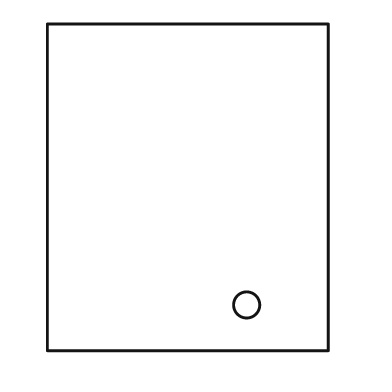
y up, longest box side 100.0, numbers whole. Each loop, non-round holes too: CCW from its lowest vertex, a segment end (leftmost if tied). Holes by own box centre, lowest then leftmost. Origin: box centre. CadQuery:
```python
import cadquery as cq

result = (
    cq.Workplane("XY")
    .moveTo(-43.0, -50.0)
    .lineTo(43.0, -50.0)
    .lineTo(43.0, 50.0)
    .lineTo(-43.0, 50.0)
    .close()
    .moveTo(18.0, -36.0)
    .circle(4.0)
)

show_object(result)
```